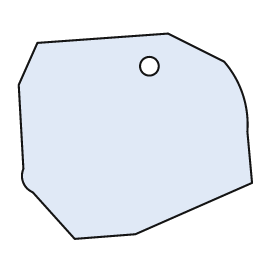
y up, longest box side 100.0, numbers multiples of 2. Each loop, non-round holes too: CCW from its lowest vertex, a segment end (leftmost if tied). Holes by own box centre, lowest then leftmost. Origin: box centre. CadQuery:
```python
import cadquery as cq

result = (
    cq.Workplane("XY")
    .moveTo(-26.0, -44.0)
    .lineTo(0.0, -42.0)
    .lineTo(50.0, -20.0)
    .lineTo(48.0, 2.0)
    .threePointArc((46.0, 18.0), (38.0, 32.0))
    .lineTo(14.0, 44.0)
    .lineTo(-42.0, 40.0)
    .lineTo(-50.0, 22.0)
    .lineTo(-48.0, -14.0)
    .threePointArc((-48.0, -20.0), (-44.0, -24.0))
    .close()
    .moveTo(6.0, 30.0)
    .circle(4.0)
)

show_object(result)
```